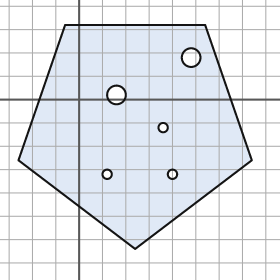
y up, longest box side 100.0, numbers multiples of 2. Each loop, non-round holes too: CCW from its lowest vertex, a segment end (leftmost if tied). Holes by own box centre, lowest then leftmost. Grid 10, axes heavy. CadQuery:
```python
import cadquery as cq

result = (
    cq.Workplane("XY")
    .moveTo(24.0, -64.0)
    .lineTo(74.0, -26.0)
    .lineTo(54.0, 32.0)
    .lineTo(-6.0, 32.0)
    .lineTo(-26.0, -26.0)
    .close()
    .moveTo(12.0, -32.0)
    .circle(2.0)
    .moveTo(40.0, -32.0)
    .circle(2.0)
    .moveTo(36.0, -12.0)
    .circle(2.0)
    .moveTo(16.0, 2.0)
    .circle(4.0)
    .moveTo(48.0, 18.0)
    .circle(4.0)
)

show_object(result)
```